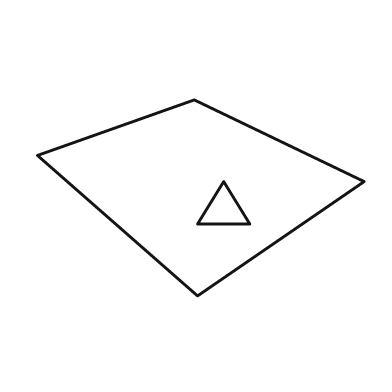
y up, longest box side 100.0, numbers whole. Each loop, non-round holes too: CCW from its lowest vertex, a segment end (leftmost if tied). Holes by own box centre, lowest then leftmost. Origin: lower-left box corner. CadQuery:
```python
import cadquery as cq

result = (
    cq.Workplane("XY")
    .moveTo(49.0, 0.0)
    .lineTo(100.0, 35.0)
    .lineTo(48.0, 60.0)
    .lineTo(0.0, 43.0)
    .close()
    .moveTo(49.0, 22.0)
    .lineTo(65.0, 22.0)
    .lineTo(57.0, 35.0)
    .close()
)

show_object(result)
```